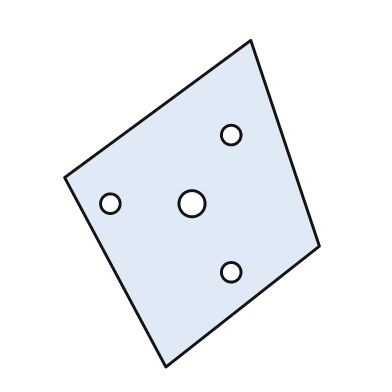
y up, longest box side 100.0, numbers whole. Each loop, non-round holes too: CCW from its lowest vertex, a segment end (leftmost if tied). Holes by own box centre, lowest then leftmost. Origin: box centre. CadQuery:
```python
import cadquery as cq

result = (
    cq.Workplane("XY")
    .moveTo(-8.0, -50.0)
    .lineTo(39.0, -13.0)
    .lineTo(18.0, 50.0)
    .lineTo(-39.0, 8.0)
    .close()
    .moveTo(12.0, -21.0)
    .circle(3.0)
    .moveTo(-25.0, 0.0)
    .circle(3.0)
    .moveTo(0.0, 0.0)
    .circle(4.0)
    .moveTo(12.0, 21.0)
    .circle(3.0)
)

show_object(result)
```